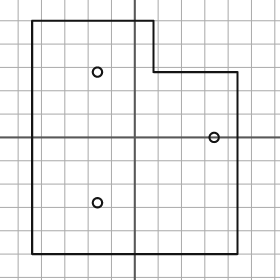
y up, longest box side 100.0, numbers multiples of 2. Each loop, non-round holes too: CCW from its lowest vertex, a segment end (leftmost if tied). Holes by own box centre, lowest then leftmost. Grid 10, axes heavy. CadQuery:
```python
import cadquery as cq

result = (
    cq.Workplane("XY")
    .moveTo(-44.0, -50.0)
    .lineTo(44.0, -50.0)
    .lineTo(44.0, 28.0)
    .lineTo(8.0, 28.0)
    .lineTo(8.0, 50.0)
    .lineTo(-44.0, 50.0)
    .close()
    .moveTo(-16.0, -28.0)
    .circle(2.0)
    .moveTo(34.0, 0.0)
    .circle(2.0)
    .moveTo(-16.0, 28.0)
    .circle(2.0)
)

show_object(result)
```